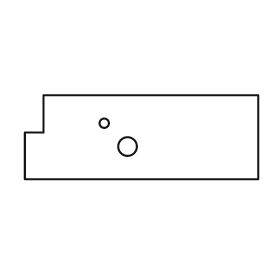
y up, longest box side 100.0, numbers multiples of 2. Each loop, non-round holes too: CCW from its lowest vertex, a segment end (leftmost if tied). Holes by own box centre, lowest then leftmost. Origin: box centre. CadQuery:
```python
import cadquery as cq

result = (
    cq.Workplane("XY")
    .moveTo(-50.0, -18.0)
    .lineTo(50.0, -18.0)
    .lineTo(50.0, 18.0)
    .lineTo(-42.0, 18.0)
    .lineTo(-42.0, 2.0)
    .lineTo(-50.0, 2.0)
    .close()
    .moveTo(-6.0, -4.0)
    .circle(4.0)
    .moveTo(-16.0, 6.0)
    .circle(2.0)
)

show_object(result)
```